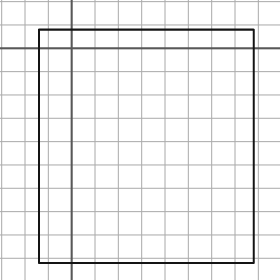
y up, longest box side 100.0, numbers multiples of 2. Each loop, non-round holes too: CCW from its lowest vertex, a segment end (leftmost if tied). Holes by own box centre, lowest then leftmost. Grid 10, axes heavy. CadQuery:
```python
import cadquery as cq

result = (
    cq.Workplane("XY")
    .moveTo(-14.0, -92.0)
    .lineTo(78.0, -92.0)
    .lineTo(78.0, 8.0)
    .lineTo(-14.0, 8.0)
    .close()
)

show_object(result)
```